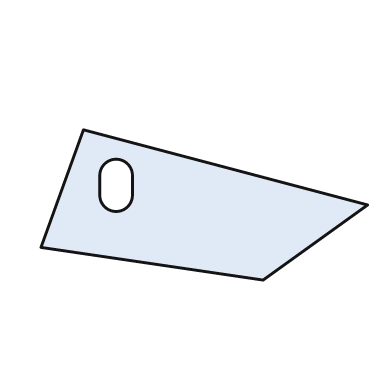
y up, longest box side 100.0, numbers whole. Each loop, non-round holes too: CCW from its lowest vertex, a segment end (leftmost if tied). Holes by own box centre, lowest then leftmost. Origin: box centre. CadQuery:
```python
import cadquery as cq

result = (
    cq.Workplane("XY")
    .moveTo(18.0, -23.0)
    .lineTo(50.0, 0.0)
    .lineTo(-37.0, 23.0)
    .lineTo(-50.0, -13.0)
    .close()
    .moveTo(-32.0, 3.0)
    .threePointArc((-27.0, -2.0), (-22.0, 3.0))
    .lineTo(-22.0, 9.0)
    .threePointArc((-27.0, 14.0), (-32.0, 9.0))
    .close()
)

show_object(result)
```